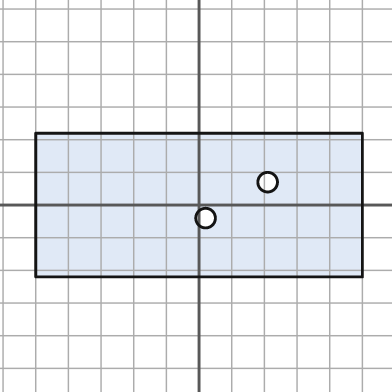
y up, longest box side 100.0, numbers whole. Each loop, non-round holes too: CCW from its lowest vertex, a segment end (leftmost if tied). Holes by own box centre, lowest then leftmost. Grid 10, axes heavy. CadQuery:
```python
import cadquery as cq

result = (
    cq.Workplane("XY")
    .moveTo(-50.0, -22.0)
    .lineTo(50.0, -22.0)
    .lineTo(50.0, 22.0)
    .lineTo(-50.0, 22.0)
    .close()
    .moveTo(2.0, -4.0)
    .circle(3.0)
    .moveTo(21.0, 7.0)
    .circle(3.0)
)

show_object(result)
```